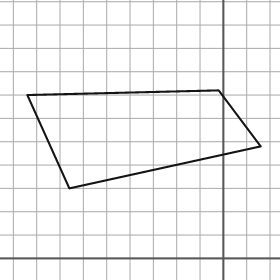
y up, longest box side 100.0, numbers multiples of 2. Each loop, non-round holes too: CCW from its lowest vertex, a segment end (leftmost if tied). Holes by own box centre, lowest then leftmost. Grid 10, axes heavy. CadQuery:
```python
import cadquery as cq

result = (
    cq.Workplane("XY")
    .moveTo(-66.0, 30.0)
    .lineTo(16.0, 48.0)
    .lineTo(-2.0, 72.0)
    .lineTo(-84.0, 70.0)
    .close()
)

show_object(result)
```